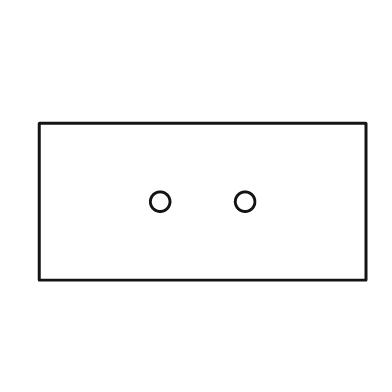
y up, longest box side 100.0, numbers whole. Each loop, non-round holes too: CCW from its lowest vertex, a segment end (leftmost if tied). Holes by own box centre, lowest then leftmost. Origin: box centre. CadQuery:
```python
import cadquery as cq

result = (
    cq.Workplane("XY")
    .moveTo(-50.0, -24.0)
    .lineTo(50.0, -24.0)
    .lineTo(50.0, 24.0)
    .lineTo(-50.0, 24.0)
    .close()
    .moveTo(-13.0, 0.0)
    .circle(3.0)
    .moveTo(13.0, 0.0)
    .circle(3.0)
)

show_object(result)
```